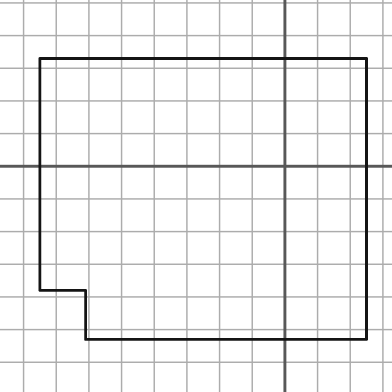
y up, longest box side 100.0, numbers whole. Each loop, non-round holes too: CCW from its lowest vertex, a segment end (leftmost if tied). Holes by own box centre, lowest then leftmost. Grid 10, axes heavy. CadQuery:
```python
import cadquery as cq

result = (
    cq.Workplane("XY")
    .moveTo(-61.0, -53.0)
    .lineTo(25.0, -53.0)
    .lineTo(25.0, 33.0)
    .lineTo(-75.0, 33.0)
    .lineTo(-75.0, -38.0)
    .lineTo(-61.0, -38.0)
    .close()
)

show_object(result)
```